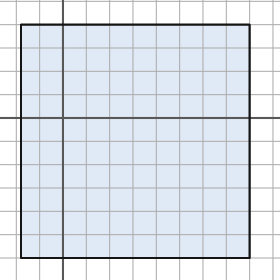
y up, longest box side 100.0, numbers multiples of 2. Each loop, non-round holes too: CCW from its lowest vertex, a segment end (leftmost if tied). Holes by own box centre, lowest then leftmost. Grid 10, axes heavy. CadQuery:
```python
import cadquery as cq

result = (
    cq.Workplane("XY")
    .moveTo(-18.0, -60.0)
    .lineTo(80.0, -60.0)
    .lineTo(80.0, 40.0)
    .lineTo(-18.0, 40.0)
    .close()
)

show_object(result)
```